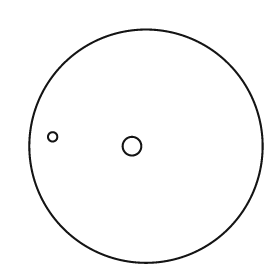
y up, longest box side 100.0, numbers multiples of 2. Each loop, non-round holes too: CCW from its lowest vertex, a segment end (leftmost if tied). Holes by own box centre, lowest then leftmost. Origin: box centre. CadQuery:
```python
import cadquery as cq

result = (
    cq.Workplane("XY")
    .moveTo(0.0, 0.0)
    .circle(50.0)
    .moveTo(-6.0, 0.0)
    .circle(4.0)
    .moveTo(-40.0, 4.0)
    .circle(2.0)
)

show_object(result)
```